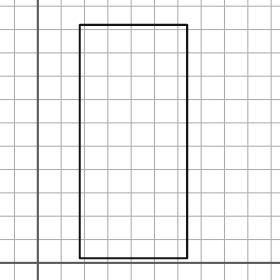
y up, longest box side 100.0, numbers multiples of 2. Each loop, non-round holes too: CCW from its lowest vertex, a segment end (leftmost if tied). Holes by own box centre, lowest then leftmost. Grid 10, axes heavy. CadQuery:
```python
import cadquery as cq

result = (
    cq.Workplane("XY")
    .moveTo(18.0, 2.0)
    .lineTo(64.0, 2.0)
    .lineTo(64.0, 102.0)
    .lineTo(18.0, 102.0)
    .close()
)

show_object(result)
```